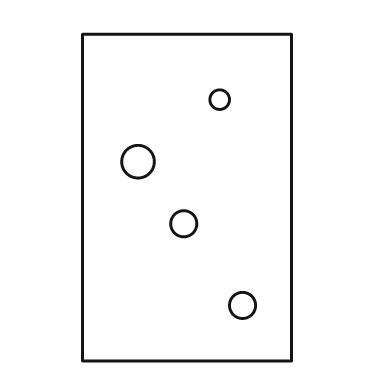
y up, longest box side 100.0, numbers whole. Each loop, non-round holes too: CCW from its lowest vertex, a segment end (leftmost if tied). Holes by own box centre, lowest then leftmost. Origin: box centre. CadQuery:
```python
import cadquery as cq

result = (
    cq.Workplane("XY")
    .moveTo(-32.0, -50.0)
    .lineTo(32.0, -50.0)
    .lineTo(32.0, 50.0)
    .lineTo(-32.0, 50.0)
    .close()
    .moveTo(17.0, -33.0)
    .circle(4.0)
    .moveTo(-1.0, -8.0)
    .circle(4.0)
    .moveTo(-15.0, 11.0)
    .circle(5.0)
    .moveTo(10.0, 30.0)
    .circle(3.0)
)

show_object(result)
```